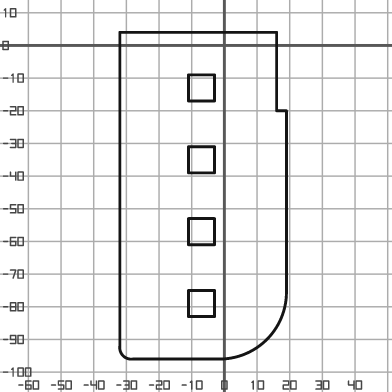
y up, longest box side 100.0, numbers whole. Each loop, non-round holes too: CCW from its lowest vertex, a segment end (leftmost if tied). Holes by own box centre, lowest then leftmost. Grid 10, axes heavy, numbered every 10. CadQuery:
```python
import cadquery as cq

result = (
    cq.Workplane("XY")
    .moveTo(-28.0, -96.0)
    .lineTo(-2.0, -96.0)
    .threePointArc((13.0, -90.0), (19.0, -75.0))
    .lineTo(19.0, -20.0)
    .lineTo(16.0, -20.0)
    .lineTo(16.0, 4.0)
    .lineTo(-32.0, 4.0)
    .lineTo(-32.0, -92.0)
    .threePointArc((-31.0, -95.0), (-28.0, -96.0))
    .close()
    .moveTo(-11.0, -83.0)
    .lineTo(-3.0, -83.0)
    .lineTo(-3.0, -75.0)
    .lineTo(-11.0, -75.0)
    .close()
    .moveTo(-11.0, -61.0)
    .lineTo(-3.0, -61.0)
    .lineTo(-3.0, -53.0)
    .lineTo(-11.0, -53.0)
    .close()
    .moveTo(-11.0, -39.0)
    .lineTo(-3.0, -39.0)
    .lineTo(-3.0, -31.0)
    .lineTo(-11.0, -31.0)
    .close()
    .moveTo(-11.0, -17.0)
    .lineTo(-3.0, -17.0)
    .lineTo(-3.0, -9.0)
    .lineTo(-11.0, -9.0)
    .close()
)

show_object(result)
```